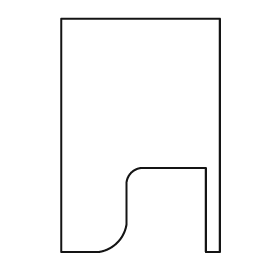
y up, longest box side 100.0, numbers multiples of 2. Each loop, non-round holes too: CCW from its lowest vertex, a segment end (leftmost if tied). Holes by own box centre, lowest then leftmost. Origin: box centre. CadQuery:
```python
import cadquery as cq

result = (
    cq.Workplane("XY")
    .moveTo(-34.0, -50.0)
    .lineTo(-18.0, -50.0)
    .threePointArc((-10.0, -46.0), (-6.0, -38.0))
    .lineTo(-6.0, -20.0)
    .threePointArc((-4.0, -16.0), (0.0, -14.0))
    .lineTo(28.0, -14.0)
    .lineTo(28.0, -50.0)
    .lineTo(34.0, -50.0)
    .lineTo(34.0, 50.0)
    .lineTo(-34.0, 50.0)
    .close()
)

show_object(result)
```